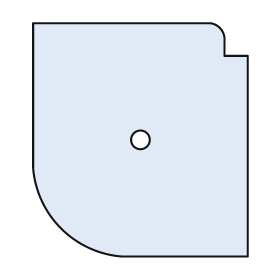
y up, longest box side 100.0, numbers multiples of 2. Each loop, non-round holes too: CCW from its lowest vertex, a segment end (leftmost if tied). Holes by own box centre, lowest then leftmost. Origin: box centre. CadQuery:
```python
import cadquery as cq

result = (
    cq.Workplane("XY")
    .moveTo(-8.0, -50.0)
    .lineTo(46.0, -50.0)
    .lineTo(46.0, 36.0)
    .lineTo(36.0, 36.0)
    .lineTo(36.0, 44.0)
    .threePointArc((34.0, 48.0), (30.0, 50.0))
    .lineTo(-46.0, 50.0)
    .lineTo(-46.0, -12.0)
    .threePointArc((-34.0, -38.0), (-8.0, -50.0))
    .close()
    .moveTo(0.0, 0.0)
    .circle(4.0)
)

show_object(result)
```